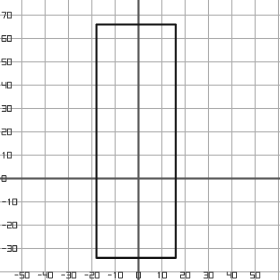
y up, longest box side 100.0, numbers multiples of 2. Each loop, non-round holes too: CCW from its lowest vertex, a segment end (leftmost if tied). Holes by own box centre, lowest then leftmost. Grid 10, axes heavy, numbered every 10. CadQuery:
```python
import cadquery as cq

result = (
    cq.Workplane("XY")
    .moveTo(-18.0, -34.0)
    .lineTo(16.0, -34.0)
    .lineTo(16.0, 66.0)
    .lineTo(-18.0, 66.0)
    .close()
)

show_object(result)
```